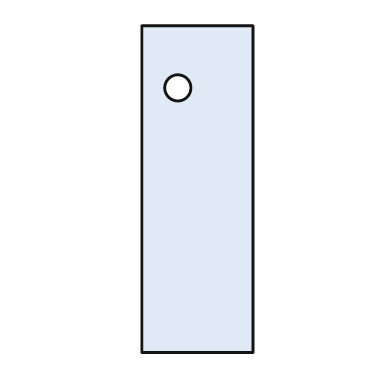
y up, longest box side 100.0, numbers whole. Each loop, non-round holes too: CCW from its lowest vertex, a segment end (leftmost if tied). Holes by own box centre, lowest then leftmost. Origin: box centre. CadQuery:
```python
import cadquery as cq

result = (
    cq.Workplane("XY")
    .moveTo(-17.0, -50.0)
    .lineTo(17.0, -50.0)
    .lineTo(17.0, 50.0)
    .lineTo(-17.0, 50.0)
    .close()
    .moveTo(-6.0, 31.0)
    .circle(4.0)
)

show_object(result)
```